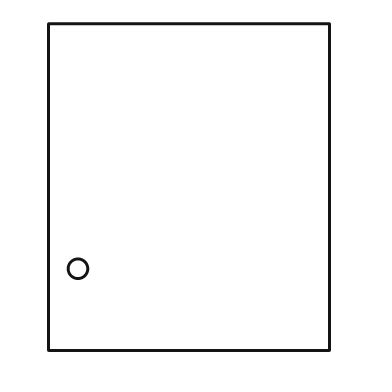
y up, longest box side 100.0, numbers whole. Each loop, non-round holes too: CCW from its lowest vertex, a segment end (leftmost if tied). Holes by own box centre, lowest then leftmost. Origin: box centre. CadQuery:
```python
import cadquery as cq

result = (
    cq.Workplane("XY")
    .moveTo(-43.0, -50.0)
    .lineTo(43.0, -50.0)
    .lineTo(43.0, 50.0)
    .lineTo(-43.0, 50.0)
    .close()
    .moveTo(-34.0, -25.0)
    .circle(3.0)
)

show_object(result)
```